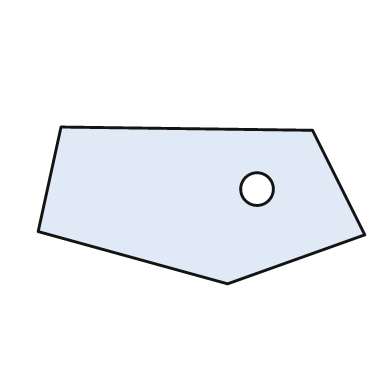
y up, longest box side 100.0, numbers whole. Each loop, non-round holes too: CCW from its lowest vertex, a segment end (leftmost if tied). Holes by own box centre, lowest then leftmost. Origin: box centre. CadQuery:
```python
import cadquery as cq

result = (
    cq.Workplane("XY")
    .moveTo(8.0, -24.0)
    .lineTo(50.0, -9.0)
    .lineTo(34.0, 23.0)
    .lineTo(-43.0, 24.0)
    .lineTo(-50.0, -8.0)
    .close()
    .moveTo(17.0, 5.0)
    .circle(5.0)
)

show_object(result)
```